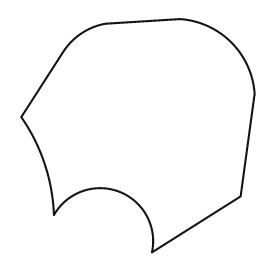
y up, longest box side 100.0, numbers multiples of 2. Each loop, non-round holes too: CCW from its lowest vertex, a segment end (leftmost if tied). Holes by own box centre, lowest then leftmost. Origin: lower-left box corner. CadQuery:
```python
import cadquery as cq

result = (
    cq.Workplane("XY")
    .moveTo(56.0, 0.0)
    .lineTo(94.0, 24.0)
    .lineTo(100.0, 68.0)
    .threePointArc((90.0, 90.0), (68.0, 100.0))
    .lineTo(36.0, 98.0)
    .threePointArc((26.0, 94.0), (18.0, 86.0))
    .lineTo(0.0, 58.0)
    .threePointArc((10.0, 38.0), (14.0, 16.0))
    .threePointArc((42.0, 26.0), (56.0, 0.0))
    .close()
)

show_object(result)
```